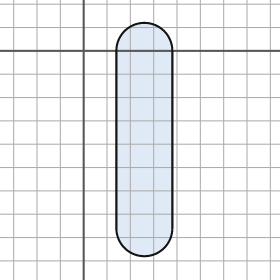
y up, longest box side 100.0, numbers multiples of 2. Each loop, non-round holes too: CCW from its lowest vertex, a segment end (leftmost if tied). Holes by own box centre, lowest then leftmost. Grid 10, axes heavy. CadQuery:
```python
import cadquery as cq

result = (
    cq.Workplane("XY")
    .moveTo(14.0, -76.0)
    .threePointArc((26.0, -88.0), (38.0, -76.0))
    .lineTo(38.0, 0.0)
    .threePointArc((26.0, 12.0), (14.0, 0.0))
    .close()
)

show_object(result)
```